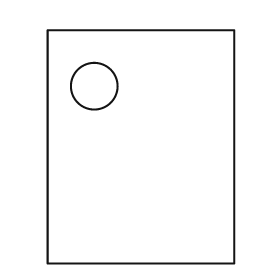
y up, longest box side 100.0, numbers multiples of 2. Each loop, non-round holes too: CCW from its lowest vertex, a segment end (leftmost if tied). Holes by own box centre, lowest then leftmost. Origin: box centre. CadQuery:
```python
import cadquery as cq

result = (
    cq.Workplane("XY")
    .moveTo(-40.0, -50.0)
    .lineTo(40.0, -50.0)
    .lineTo(40.0, 50.0)
    .lineTo(-40.0, 50.0)
    .close()
    .moveTo(-20.0, 26.0)
    .circle(10.0)
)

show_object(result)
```